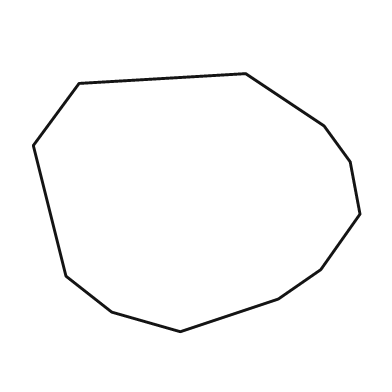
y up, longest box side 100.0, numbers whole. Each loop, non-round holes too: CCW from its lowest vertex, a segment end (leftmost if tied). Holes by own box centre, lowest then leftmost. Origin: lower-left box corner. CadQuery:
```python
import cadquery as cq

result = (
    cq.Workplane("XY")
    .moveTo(45.0, 0.0)
    .lineTo(75.0, 10.0)
    .lineTo(88.0, 19.0)
    .lineTo(100.0, 36.0)
    .lineTo(97.0, 52.0)
    .lineTo(89.0, 63.0)
    .lineTo(65.0, 79.0)
    .lineTo(14.0, 76.0)
    .lineTo(0.0, 57.0)
    .lineTo(10.0, 17.0)
    .lineTo(24.0, 6.0)
    .close()
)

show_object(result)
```